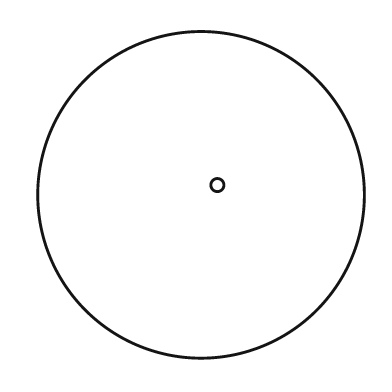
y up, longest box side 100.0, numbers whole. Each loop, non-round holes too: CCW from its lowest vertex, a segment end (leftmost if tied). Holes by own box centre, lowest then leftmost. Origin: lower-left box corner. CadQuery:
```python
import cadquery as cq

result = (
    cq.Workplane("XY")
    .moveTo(50.0, 50.0)
    .circle(50.0)
    .moveTo(55.0, 53.0)
    .circle(2.0)
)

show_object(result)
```